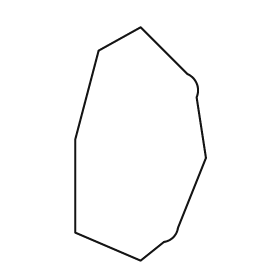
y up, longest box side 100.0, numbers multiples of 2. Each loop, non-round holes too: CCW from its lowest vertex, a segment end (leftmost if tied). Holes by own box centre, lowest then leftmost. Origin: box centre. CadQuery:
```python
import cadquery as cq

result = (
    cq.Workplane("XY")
    .moveTo(0.0, -50.0)
    .lineTo(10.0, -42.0)
    .threePointArc((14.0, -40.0), (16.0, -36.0))
    .lineTo(28.0, -6.0)
    .lineTo(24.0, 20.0)
    .threePointArc((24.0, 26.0), (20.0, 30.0))
    .lineTo(0.0, 50.0)
    .lineTo(-18.0, 40.0)
    .lineTo(-28.0, 2.0)
    .lineTo(-28.0, -38.0)
    .close()
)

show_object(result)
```